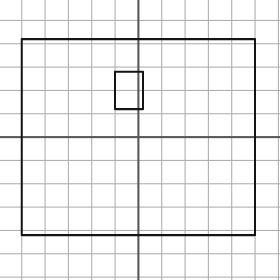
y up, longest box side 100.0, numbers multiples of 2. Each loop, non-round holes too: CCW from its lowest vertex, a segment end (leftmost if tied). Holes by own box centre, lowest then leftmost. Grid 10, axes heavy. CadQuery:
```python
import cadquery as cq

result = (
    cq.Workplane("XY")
    .moveTo(-50.0, -42.0)
    .lineTo(50.0, -42.0)
    .lineTo(50.0, 42.0)
    .lineTo(-50.0, 42.0)
    .close()
    .moveTo(-10.0, 12.0)
    .lineTo(2.0, 12.0)
    .lineTo(2.0, 28.0)
    .lineTo(-10.0, 28.0)
    .close()
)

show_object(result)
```